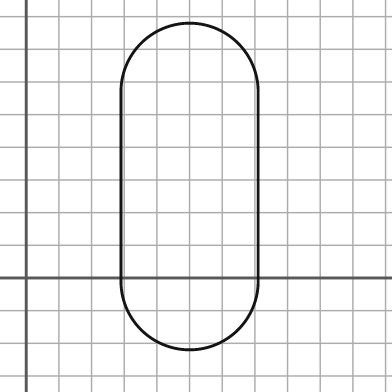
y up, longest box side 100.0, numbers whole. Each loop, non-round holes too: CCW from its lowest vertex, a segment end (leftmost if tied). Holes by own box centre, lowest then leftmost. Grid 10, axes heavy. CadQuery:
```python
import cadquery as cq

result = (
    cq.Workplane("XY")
    .moveTo(29.0, -1.0)
    .threePointArc((50.0, -22.0), (71.0, -1.0))
    .lineTo(71.0, 57.0)
    .threePointArc((50.0, 78.0), (29.0, 57.0))
    .close()
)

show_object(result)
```